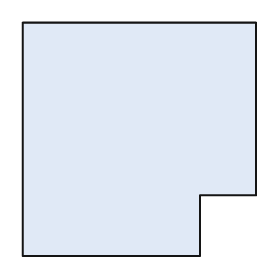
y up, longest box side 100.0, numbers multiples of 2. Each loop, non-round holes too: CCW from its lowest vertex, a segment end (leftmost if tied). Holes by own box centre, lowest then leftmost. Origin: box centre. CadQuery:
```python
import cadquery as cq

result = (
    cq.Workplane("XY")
    .moveTo(-50.0, -50.0)
    .lineTo(26.0, -50.0)
    .lineTo(26.0, -24.0)
    .lineTo(50.0, -24.0)
    .lineTo(50.0, 50.0)
    .lineTo(-50.0, 50.0)
    .close()
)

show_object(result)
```